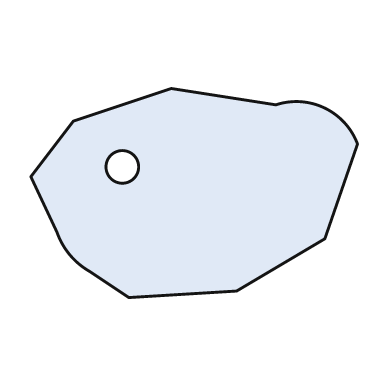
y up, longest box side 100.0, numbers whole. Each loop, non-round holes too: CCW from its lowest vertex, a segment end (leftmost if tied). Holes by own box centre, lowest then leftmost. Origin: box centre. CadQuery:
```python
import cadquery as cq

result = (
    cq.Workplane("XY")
    .moveTo(-20.0, -32.0)
    .lineTo(13.0, -30.0)
    .lineTo(40.0, -14.0)
    .lineTo(50.0, 15.0)
    .threePointArc((40.0, 26.0), (25.0, 27.0))
    .lineTo(-7.0, 32.0)
    .lineTo(-37.0, 22.0)
    .lineTo(-50.0, 5.0)
    .lineTo(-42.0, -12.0)
    .threePointArc((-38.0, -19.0), (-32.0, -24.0))
    .close()
    .moveTo(-22.0, 8.0)
    .circle(5.0)
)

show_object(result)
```